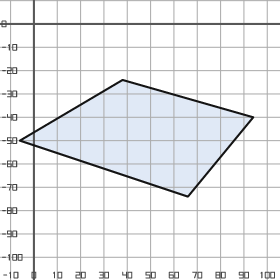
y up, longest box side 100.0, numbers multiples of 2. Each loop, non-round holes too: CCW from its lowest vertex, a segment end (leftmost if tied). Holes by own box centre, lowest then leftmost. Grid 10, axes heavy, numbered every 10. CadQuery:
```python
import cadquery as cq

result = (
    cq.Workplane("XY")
    .moveTo(66.0, -74.0)
    .lineTo(94.0, -40.0)
    .lineTo(38.0, -24.0)
    .lineTo(-6.0, -50.0)
    .close()
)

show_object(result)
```